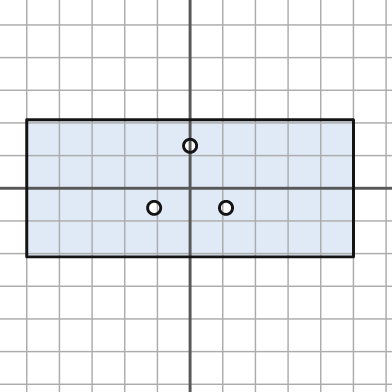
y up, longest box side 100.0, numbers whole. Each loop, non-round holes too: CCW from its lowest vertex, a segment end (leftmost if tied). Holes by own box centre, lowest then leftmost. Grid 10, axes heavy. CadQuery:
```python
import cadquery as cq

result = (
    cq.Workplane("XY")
    .moveTo(-50.0, -21.0)
    .lineTo(50.0, -21.0)
    .lineTo(50.0, 21.0)
    .lineTo(-50.0, 21.0)
    .close()
    .moveTo(-11.0, -6.0)
    .circle(2.0)
    .moveTo(11.0, -6.0)
    .circle(2.0)
    .moveTo(0.0, 13.0)
    .circle(2.0)
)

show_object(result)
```